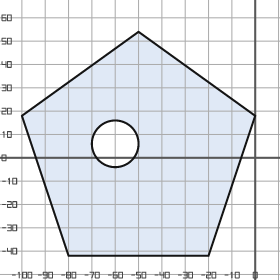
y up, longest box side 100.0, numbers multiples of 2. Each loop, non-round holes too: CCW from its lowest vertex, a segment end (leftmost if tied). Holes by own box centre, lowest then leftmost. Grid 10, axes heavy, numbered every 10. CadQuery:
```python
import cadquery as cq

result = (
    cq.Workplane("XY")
    .moveTo(-80.0, -42.0)
    .lineTo(-20.0, -42.0)
    .lineTo(0.0, 18.0)
    .lineTo(-50.0, 54.0)
    .lineTo(-100.0, 18.0)
    .close()
    .moveTo(-60.0, 6.0)
    .circle(10.0)
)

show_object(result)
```